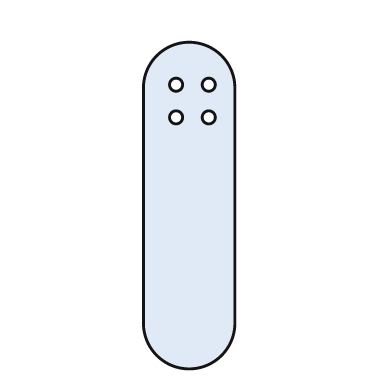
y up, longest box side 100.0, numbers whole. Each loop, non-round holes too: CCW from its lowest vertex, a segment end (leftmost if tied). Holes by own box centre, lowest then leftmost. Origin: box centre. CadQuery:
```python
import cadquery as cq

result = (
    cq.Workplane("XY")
    .moveTo(-14.0, -36.0)
    .threePointArc((0.0, -50.0), (14.0, -36.0))
    .lineTo(14.0, 36.0)
    .threePointArc((0.0, 50.0), (-14.0, 36.0))
    .close()
    .moveTo(-4.0, 27.0)
    .circle(2.0)
    .moveTo(6.0, 27.0)
    .circle(2.0)
    .moveTo(-4.0, 37.0)
    .circle(2.0)
    .moveTo(6.0, 37.0)
    .circle(2.0)
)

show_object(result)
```